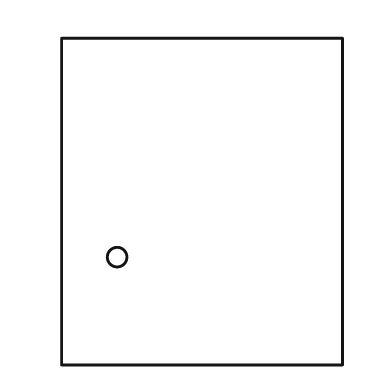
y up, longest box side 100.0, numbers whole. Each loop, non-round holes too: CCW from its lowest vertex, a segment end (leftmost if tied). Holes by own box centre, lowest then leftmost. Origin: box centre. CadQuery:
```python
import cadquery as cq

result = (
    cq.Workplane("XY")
    .moveTo(-43.0, -50.0)
    .lineTo(43.0, -50.0)
    .lineTo(43.0, 50.0)
    .lineTo(-43.0, 50.0)
    .close()
    .moveTo(-26.0, -17.0)
    .circle(3.0)
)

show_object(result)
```